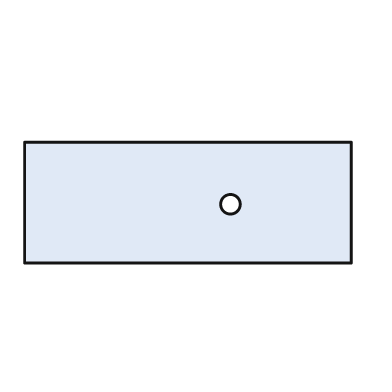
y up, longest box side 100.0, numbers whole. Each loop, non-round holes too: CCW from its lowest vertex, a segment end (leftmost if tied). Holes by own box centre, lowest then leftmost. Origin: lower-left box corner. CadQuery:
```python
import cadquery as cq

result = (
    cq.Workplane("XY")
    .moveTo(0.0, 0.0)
    .lineTo(100.0, 0.0)
    .lineTo(100.0, 37.0)
    .lineTo(0.0, 37.0)
    .close()
    .moveTo(63.0, 18.0)
    .circle(3.0)
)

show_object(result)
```